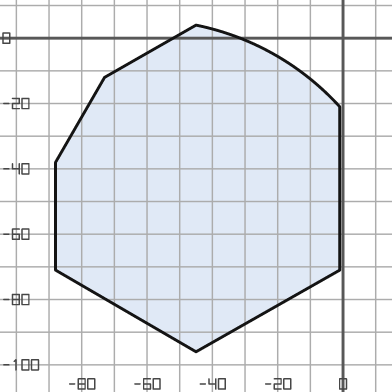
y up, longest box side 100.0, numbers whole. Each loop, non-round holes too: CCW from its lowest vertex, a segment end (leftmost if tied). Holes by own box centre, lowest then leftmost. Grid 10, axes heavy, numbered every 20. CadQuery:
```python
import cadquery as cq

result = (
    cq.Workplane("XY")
    .moveTo(-45.0, -96.0)
    .lineTo(-1.0, -71.0)
    .lineTo(-1.0, -21.0)
    .threePointArc((-21.0, -5.0), (-45.0, 4.0))
    .lineTo(-73.0, -12.0)
    .lineTo(-88.0, -38.0)
    .lineTo(-88.0, -71.0)
    .close()
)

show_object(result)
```